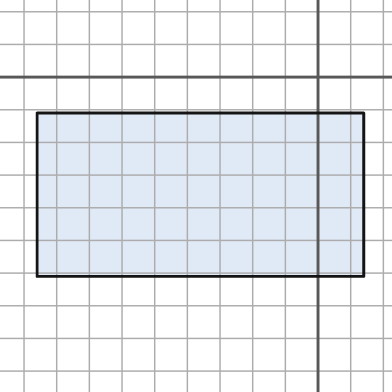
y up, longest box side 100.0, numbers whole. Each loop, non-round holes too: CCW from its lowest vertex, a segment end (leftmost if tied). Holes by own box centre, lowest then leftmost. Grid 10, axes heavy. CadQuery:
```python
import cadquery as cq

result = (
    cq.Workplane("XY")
    .moveTo(-86.0, -61.0)
    .lineTo(14.0, -61.0)
    .lineTo(14.0, -11.0)
    .lineTo(-86.0, -11.0)
    .close()
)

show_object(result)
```